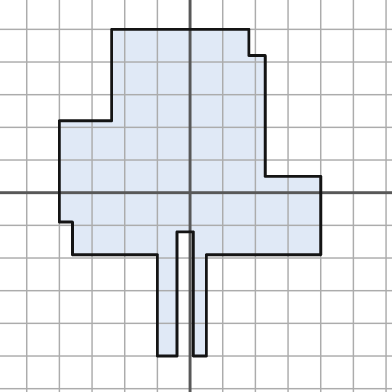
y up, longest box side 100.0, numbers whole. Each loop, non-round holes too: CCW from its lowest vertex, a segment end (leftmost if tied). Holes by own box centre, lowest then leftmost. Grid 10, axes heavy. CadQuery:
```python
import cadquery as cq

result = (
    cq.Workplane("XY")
    .moveTo(-10.0, -50.0)
    .lineTo(-4.0, -50.0)
    .lineTo(-4.0, -12.0)
    .lineTo(1.0, -12.0)
    .lineTo(1.0, -50.0)
    .lineTo(5.0, -50.0)
    .lineTo(5.0, -19.0)
    .lineTo(40.0, -19.0)
    .lineTo(40.0, 5.0)
    .lineTo(23.0, 5.0)
    .lineTo(23.0, 42.0)
    .lineTo(18.0, 42.0)
    .lineTo(18.0, 50.0)
    .lineTo(-24.0, 50.0)
    .lineTo(-24.0, 22.0)
    .lineTo(-40.0, 22.0)
    .lineTo(-40.0, -9.0)
    .lineTo(-36.0, -9.0)
    .lineTo(-36.0, -19.0)
    .lineTo(-10.0, -19.0)
    .close()
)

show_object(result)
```